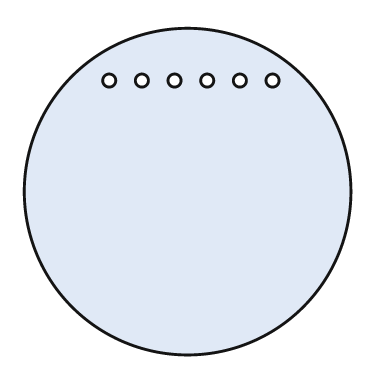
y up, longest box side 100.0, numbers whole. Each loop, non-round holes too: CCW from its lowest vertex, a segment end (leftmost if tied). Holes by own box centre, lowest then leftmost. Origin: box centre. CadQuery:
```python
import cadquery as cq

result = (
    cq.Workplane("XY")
    .moveTo(0.0, 0.0)
    .circle(50.0)
    .moveTo(-24.0, 34.0)
    .circle(2.0)
    .moveTo(-14.0, 34.0)
    .circle(2.0)
    .moveTo(-4.0, 34.0)
    .circle(2.0)
    .moveTo(6.0, 34.0)
    .circle(2.0)
    .moveTo(16.0, 34.0)
    .circle(2.0)
    .moveTo(26.0, 34.0)
    .circle(2.0)
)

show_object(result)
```